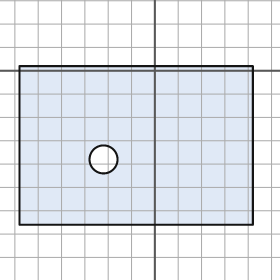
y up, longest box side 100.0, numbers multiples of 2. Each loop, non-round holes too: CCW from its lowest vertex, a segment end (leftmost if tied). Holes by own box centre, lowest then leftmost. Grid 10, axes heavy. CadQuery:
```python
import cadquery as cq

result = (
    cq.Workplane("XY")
    .moveTo(-58.0, -66.0)
    .lineTo(42.0, -66.0)
    .lineTo(42.0, 2.0)
    .lineTo(-58.0, 2.0)
    .close()
    .moveTo(-22.0, -38.0)
    .circle(6.0)
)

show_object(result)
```